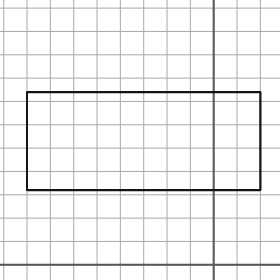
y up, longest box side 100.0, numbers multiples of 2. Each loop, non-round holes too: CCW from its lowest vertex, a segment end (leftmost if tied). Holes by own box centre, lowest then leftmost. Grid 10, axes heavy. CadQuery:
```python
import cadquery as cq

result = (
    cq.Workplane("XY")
    .moveTo(-80.0, 32.0)
    .lineTo(20.0, 32.0)
    .lineTo(20.0, 74.0)
    .lineTo(-80.0, 74.0)
    .close()
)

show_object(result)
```